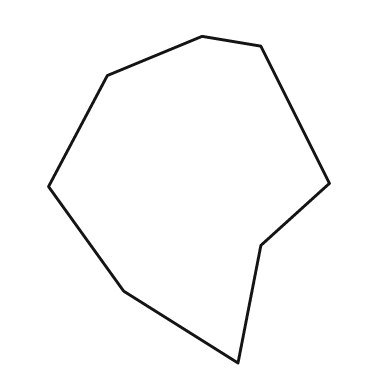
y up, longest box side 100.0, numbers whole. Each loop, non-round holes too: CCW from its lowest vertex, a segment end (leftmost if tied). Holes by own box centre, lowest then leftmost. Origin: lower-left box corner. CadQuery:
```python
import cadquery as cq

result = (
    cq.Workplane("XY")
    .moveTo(58.0, 0.0)
    .lineTo(65.0, 36.0)
    .lineTo(86.0, 55.0)
    .lineTo(65.0, 97.0)
    .lineTo(47.0, 100.0)
    .lineTo(18.0, 88.0)
    .lineTo(0.0, 54.0)
    .lineTo(23.0, 22.0)
    .close()
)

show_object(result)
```